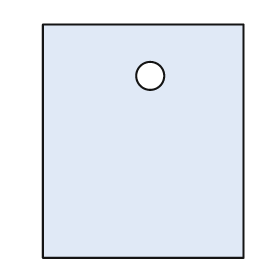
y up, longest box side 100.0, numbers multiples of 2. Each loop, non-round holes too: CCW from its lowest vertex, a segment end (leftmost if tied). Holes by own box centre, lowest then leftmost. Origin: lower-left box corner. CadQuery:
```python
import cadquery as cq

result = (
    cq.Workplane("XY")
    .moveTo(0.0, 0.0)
    .lineTo(86.0, 0.0)
    .lineTo(86.0, 100.0)
    .lineTo(0.0, 100.0)
    .close()
    .moveTo(46.0, 78.0)
    .circle(6.0)
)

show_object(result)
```